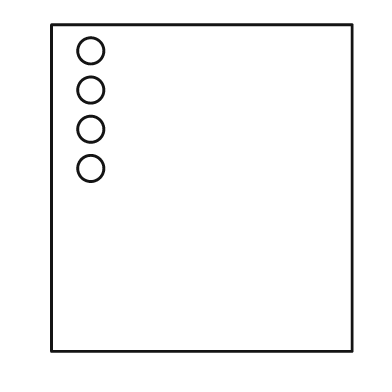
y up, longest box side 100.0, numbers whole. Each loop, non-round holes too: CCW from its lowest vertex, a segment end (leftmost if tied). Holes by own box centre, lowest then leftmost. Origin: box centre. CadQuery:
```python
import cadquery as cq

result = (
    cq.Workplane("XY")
    .moveTo(-46.0, -50.0)
    .lineTo(46.0, -50.0)
    .lineTo(46.0, 50.0)
    .lineTo(-46.0, 50.0)
    .close()
    .moveTo(-34.0, 6.0)
    .circle(4.0)
    .moveTo(-34.0, 18.0)
    .circle(4.0)
    .moveTo(-34.0, 30.0)
    .circle(4.0)
    .moveTo(-34.0, 42.0)
    .circle(4.0)
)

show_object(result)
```